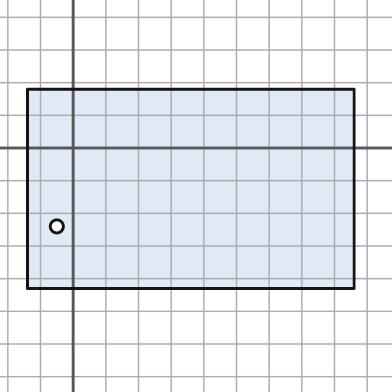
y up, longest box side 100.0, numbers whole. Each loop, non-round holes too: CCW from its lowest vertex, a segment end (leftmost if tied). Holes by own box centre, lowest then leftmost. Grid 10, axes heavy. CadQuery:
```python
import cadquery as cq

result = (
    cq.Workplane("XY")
    .moveTo(-14.0, -43.0)
    .lineTo(86.0, -43.0)
    .lineTo(86.0, 18.0)
    .lineTo(-14.0, 18.0)
    .close()
    .moveTo(-5.0, -24.0)
    .circle(2.0)
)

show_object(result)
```